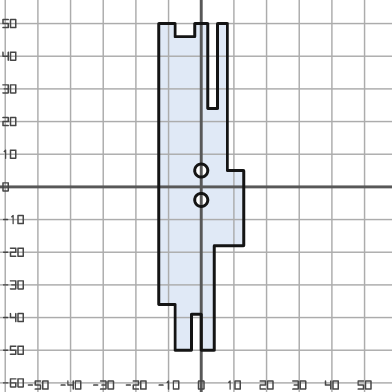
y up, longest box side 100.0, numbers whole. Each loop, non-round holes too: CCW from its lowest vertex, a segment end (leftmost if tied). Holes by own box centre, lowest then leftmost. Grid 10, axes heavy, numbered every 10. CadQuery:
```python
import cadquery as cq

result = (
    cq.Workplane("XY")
    .moveTo(-8.0, -50.0)
    .lineTo(-3.0, -50.0)
    .lineTo(-3.0, -39.0)
    .lineTo(0.0, -39.0)
    .lineTo(0.0, -50.0)
    .lineTo(4.0, -50.0)
    .lineTo(4.0, -18.0)
    .lineTo(13.0, -18.0)
    .lineTo(13.0, 5.0)
    .lineTo(8.0, 5.0)
    .lineTo(8.0, 50.0)
    .lineTo(5.0, 50.0)
    .lineTo(5.0, 24.0)
    .lineTo(2.0, 24.0)
    .lineTo(2.0, 50.0)
    .lineTo(-2.0, 50.0)
    .lineTo(-2.0, 46.0)
    .lineTo(-8.0, 46.0)
    .lineTo(-8.0, 50.0)
    .lineTo(-13.0, 50.0)
    .lineTo(-13.0, -36.0)
    .lineTo(-8.0, -36.0)
    .close()
    .moveTo(0.0, -4.0)
    .circle(2.0)
    .moveTo(0.0, 5.0)
    .circle(2.0)
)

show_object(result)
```